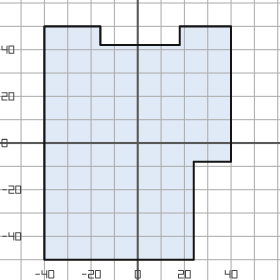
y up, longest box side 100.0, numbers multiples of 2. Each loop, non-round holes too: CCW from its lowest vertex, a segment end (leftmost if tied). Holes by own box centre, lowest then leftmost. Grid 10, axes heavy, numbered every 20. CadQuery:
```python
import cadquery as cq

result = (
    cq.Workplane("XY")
    .moveTo(-40.0, -50.0)
    .lineTo(24.0, -50.0)
    .lineTo(24.0, -8.0)
    .lineTo(40.0, -8.0)
    .lineTo(40.0, 50.0)
    .lineTo(18.0, 50.0)
    .lineTo(18.0, 42.0)
    .lineTo(-16.0, 42.0)
    .lineTo(-16.0, 50.0)
    .lineTo(-40.0, 50.0)
    .close()
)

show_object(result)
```